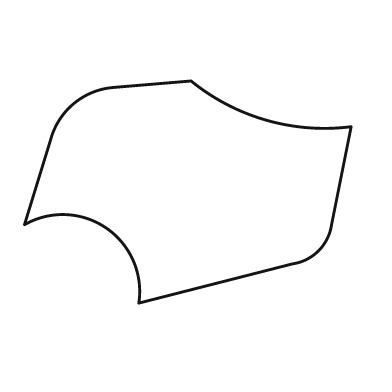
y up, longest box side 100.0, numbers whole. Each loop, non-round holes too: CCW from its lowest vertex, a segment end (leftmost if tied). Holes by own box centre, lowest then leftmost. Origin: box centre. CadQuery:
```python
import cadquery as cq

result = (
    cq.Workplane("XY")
    .moveTo(-15.0, -34.0)
    .lineTo(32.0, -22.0)
    .threePointArc((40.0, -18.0), (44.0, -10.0))
    .lineTo(50.0, 20.0)
    .threePointArc((24.0, 22.0), (1.0, 34.0))
    .lineTo(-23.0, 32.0)
    .threePointArc((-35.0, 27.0), (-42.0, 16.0))
    .lineTo(-50.0, -10.0)
    .threePointArc((-25.0, -11.0), (-15.0, -34.0))
    .close()
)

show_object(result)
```